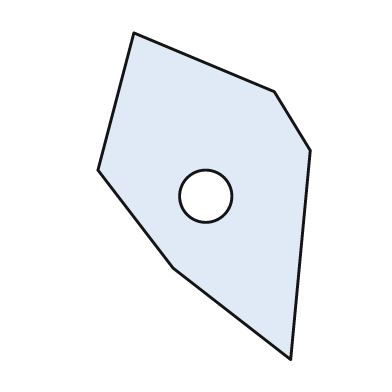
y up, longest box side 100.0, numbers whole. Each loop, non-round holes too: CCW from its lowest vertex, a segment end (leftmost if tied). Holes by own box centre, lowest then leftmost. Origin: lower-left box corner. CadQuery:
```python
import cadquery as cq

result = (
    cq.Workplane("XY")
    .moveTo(59.0, 0.0)
    .lineTo(65.0, 64.0)
    .lineTo(54.0, 82.0)
    .lineTo(11.0, 100.0)
    .lineTo(0.0, 58.0)
    .lineTo(23.0, 28.0)
    .close()
    .moveTo(33.0, 50.0)
    .circle(8.0)
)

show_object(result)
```